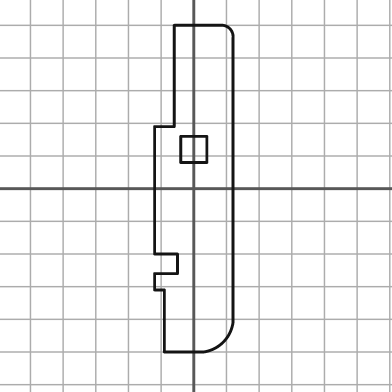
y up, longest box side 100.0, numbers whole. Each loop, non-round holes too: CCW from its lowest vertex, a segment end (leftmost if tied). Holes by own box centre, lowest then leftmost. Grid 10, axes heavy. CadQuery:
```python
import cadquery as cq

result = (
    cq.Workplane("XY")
    .moveTo(-9.0, -50.0)
    .lineTo(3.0, -50.0)
    .threePointArc((9.0, -47.0), (12.0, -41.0))
    .lineTo(12.0, 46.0)
    .threePointArc((11.0, 49.0), (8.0, 50.0))
    .lineTo(-6.0, 50.0)
    .lineTo(-6.0, 19.0)
    .lineTo(-12.0, 19.0)
    .lineTo(-12.0, -20.0)
    .lineTo(-5.0, -20.0)
    .lineTo(-5.0, -26.0)
    .lineTo(-12.0, -26.0)
    .lineTo(-12.0, -31.0)
    .lineTo(-9.0, -31.0)
    .close()
    .moveTo(-4.0, 8.0)
    .lineTo(4.0, 8.0)
    .lineTo(4.0, 16.0)
    .lineTo(-4.0, 16.0)
    .close()
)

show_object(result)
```